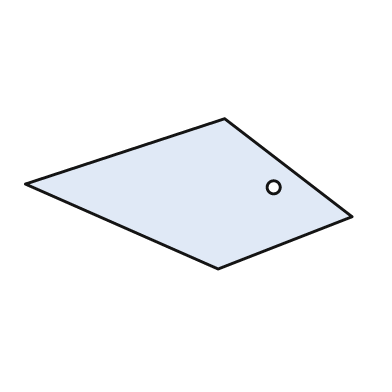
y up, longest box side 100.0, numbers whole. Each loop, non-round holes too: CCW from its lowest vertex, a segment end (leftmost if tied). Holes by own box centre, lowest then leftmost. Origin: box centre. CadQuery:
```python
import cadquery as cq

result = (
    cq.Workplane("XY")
    .moveTo(9.0, -23.0)
    .lineTo(50.0, -7.0)
    .lineTo(11.0, 23.0)
    .lineTo(-50.0, 3.0)
    .close()
    .moveTo(26.0, 2.0)
    .circle(2.0)
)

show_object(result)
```